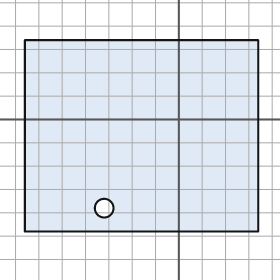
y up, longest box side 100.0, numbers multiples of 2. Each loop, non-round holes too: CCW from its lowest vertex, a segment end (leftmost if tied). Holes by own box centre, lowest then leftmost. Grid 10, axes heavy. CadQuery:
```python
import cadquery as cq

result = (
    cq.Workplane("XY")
    .moveTo(-66.0, -48.0)
    .lineTo(34.0, -48.0)
    .lineTo(34.0, 34.0)
    .lineTo(-66.0, 34.0)
    .close()
    .moveTo(-32.0, -38.0)
    .circle(4.0)
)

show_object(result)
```